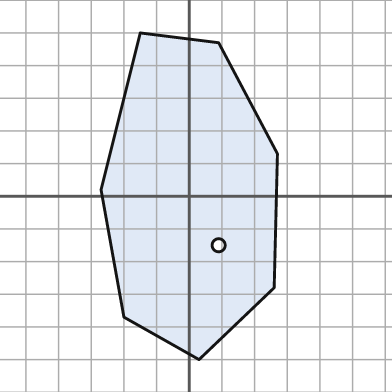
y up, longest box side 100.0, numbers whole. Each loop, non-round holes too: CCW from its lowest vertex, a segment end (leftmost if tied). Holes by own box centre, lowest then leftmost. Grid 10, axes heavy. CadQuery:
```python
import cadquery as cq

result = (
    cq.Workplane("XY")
    .moveTo(3.0, -50.0)
    .lineTo(26.0, -28.0)
    .lineTo(27.0, 13.0)
    .lineTo(9.0, 47.0)
    .lineTo(-15.0, 50.0)
    .lineTo(-27.0, 2.0)
    .lineTo(-20.0, -37.0)
    .close()
    .moveTo(9.0, -15.0)
    .circle(2.0)
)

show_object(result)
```